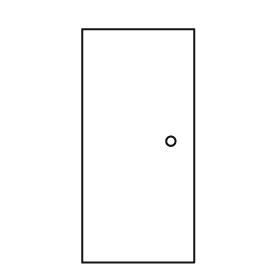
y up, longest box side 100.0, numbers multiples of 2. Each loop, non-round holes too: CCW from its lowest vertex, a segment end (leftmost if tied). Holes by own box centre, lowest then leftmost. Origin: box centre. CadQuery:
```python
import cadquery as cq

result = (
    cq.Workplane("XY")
    .moveTo(-24.0, -50.0)
    .lineTo(24.0, -50.0)
    .lineTo(24.0, 50.0)
    .lineTo(-24.0, 50.0)
    .close()
    .moveTo(14.0, 2.0)
    .circle(2.0)
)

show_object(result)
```